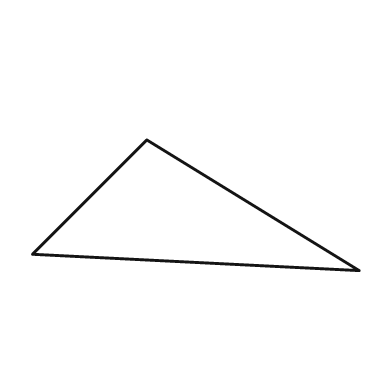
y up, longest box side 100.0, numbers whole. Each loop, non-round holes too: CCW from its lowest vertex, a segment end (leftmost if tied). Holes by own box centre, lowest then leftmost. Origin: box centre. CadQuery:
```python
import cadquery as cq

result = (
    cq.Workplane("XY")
    .moveTo(50.0, -20.0)
    .lineTo(-15.0, 20.0)
    .lineTo(-50.0, -15.0)
    .close()
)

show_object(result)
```